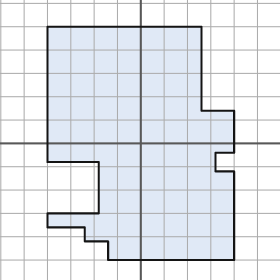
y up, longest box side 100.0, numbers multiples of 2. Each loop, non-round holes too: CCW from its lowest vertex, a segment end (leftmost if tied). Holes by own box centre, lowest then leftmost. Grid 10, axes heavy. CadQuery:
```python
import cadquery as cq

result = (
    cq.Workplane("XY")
    .moveTo(-14.0, -50.0)
    .lineTo(40.0, -50.0)
    .lineTo(40.0, -12.0)
    .lineTo(32.0, -12.0)
    .lineTo(32.0, -4.0)
    .lineTo(40.0, -4.0)
    .lineTo(40.0, 14.0)
    .lineTo(26.0, 14.0)
    .lineTo(26.0, 50.0)
    .lineTo(-40.0, 50.0)
    .lineTo(-40.0, -8.0)
    .lineTo(-18.0, -8.0)
    .lineTo(-18.0, -30.0)
    .lineTo(-40.0, -30.0)
    .lineTo(-40.0, -36.0)
    .lineTo(-24.0, -36.0)
    .lineTo(-24.0, -42.0)
    .lineTo(-14.0, -42.0)
    .close()
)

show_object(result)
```